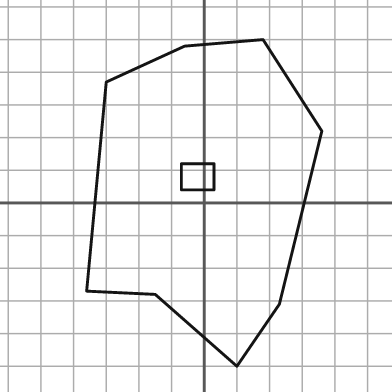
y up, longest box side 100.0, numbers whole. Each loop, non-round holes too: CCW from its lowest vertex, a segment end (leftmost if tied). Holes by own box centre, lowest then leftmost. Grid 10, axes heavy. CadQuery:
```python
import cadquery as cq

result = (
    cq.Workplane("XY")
    .moveTo(10.0, -50.0)
    .lineTo(23.0, -31.0)
    .lineTo(36.0, 22.0)
    .lineTo(18.0, 50.0)
    .lineTo(-6.0, 48.0)
    .lineTo(-30.0, 37.0)
    .lineTo(-36.0, -27.0)
    .lineTo(-15.0, -28.0)
    .close()
    .moveTo(-7.0, 4.0)
    .lineTo(3.0, 4.0)
    .lineTo(3.0, 12.0)
    .lineTo(-7.0, 12.0)
    .close()
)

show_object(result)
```